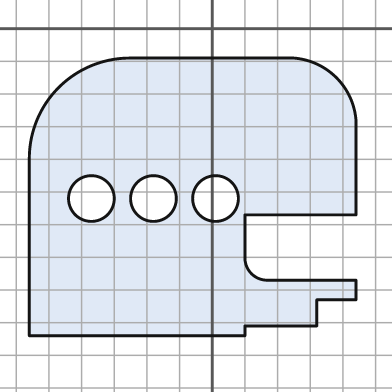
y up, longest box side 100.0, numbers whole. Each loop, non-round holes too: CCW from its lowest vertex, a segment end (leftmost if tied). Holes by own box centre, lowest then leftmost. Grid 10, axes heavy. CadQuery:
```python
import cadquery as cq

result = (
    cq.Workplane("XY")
    .moveTo(-56.0, -94.0)
    .lineTo(10.0, -94.0)
    .lineTo(10.0, -91.0)
    .lineTo(32.0, -91.0)
    .lineTo(32.0, -83.0)
    .lineTo(44.0, -83.0)
    .lineTo(44.0, -77.0)
    .lineTo(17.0, -77.0)
    .threePointArc((12.0, -75.0), (10.0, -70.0))
    .lineTo(10.0, -57.0)
    .lineTo(44.0, -57.0)
    .lineTo(44.0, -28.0)
    .threePointArc((38.0, -15.0), (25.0, -9.0))
    .lineTo(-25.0, -9.0)
    .threePointArc((-47.0, -18.0), (-56.0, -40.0))
    .close()
    .moveTo(-37.0, -52.0)
    .circle(7.0)
    .moveTo(-18.0, -52.0)
    .circle(7.0)
    .moveTo(1.0, -52.0)
    .circle(7.0)
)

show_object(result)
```